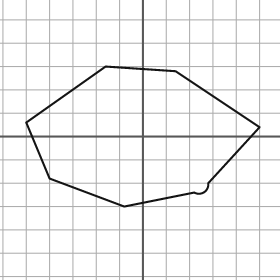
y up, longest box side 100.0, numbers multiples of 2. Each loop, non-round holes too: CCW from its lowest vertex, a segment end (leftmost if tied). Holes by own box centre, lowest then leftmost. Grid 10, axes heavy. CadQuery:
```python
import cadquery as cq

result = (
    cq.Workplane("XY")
    .moveTo(-8.0, -30.0)
    .lineTo(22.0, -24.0)
    .threePointArc((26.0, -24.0), (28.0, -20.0))
    .lineTo(50.0, 4.0)
    .lineTo(14.0, 28.0)
    .lineTo(-16.0, 30.0)
    .lineTo(-50.0, 6.0)
    .lineTo(-40.0, -18.0)
    .close()
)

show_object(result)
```